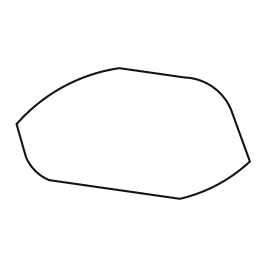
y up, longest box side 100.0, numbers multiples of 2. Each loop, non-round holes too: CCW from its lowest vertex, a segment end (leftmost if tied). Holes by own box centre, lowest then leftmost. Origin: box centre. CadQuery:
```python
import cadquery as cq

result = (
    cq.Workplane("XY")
    .moveTo(20.0, -28.0)
    .threePointArc((36.0, -22.0), (50.0, -12.0))
    .lineTo(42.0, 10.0)
    .threePointArc((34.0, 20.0), (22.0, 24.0))
    .lineTo(-6.0, 28.0)
    .threePointArc((-30.0, 20.0), (-50.0, 4.0))
    .lineTo(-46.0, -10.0)
    .threePointArc((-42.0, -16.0), (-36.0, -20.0))
    .close()
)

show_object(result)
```